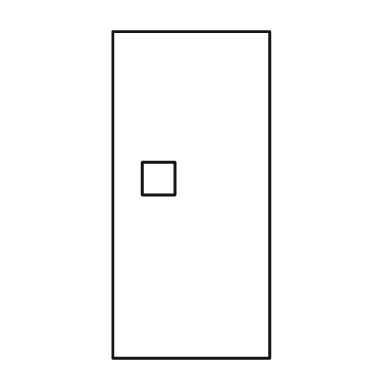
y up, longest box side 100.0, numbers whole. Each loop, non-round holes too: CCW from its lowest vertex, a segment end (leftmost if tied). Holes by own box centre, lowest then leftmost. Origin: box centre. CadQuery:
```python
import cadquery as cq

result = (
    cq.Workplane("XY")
    .moveTo(-24.0, -50.0)
    .lineTo(24.0, -50.0)
    .lineTo(24.0, 50.0)
    .lineTo(-24.0, 50.0)
    .close()
    .moveTo(-15.0, 0.0)
    .lineTo(-5.0, 0.0)
    .lineTo(-5.0, 10.0)
    .lineTo(-15.0, 10.0)
    .close()
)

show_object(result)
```